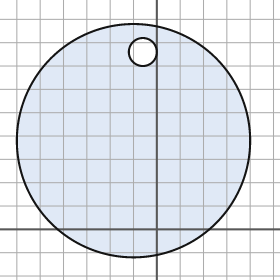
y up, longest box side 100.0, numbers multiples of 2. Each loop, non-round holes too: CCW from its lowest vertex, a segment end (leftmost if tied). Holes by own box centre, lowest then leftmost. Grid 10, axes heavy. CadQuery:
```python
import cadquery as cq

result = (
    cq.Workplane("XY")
    .moveTo(-10.0, 38.0)
    .circle(50.0)
    .moveTo(-6.0, 76.0)
    .circle(6.0)
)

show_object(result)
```